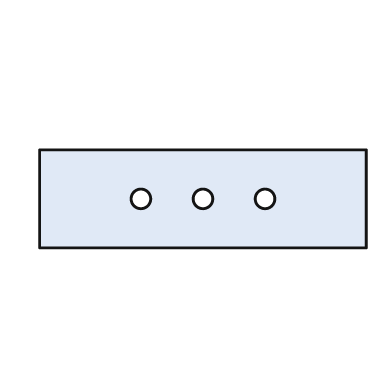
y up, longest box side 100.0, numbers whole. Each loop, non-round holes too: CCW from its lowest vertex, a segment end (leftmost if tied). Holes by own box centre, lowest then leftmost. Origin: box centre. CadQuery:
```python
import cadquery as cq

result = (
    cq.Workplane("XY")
    .moveTo(-50.0, -15.0)
    .lineTo(50.0, -15.0)
    .lineTo(50.0, 15.0)
    .lineTo(-50.0, 15.0)
    .close()
    .moveTo(-19.0, 0.0)
    .circle(3.0)
    .moveTo(0.0, 0.0)
    .circle(3.0)
    .moveTo(19.0, 0.0)
    .circle(3.0)
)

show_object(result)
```